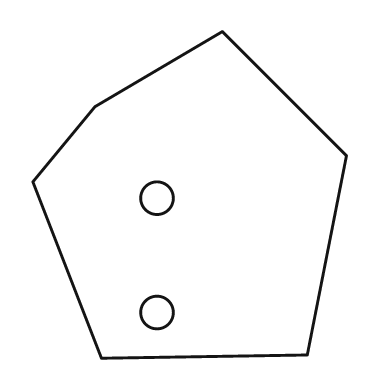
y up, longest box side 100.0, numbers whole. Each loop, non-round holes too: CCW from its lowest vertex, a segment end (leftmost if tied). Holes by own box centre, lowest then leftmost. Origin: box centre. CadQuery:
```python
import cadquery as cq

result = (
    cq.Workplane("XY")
    .moveTo(-27.0, -50.0)
    .lineTo(36.0, -49.0)
    .lineTo(48.0, 12.0)
    .lineTo(10.0, 50.0)
    .lineTo(-29.0, 27.0)
    .lineTo(-48.0, 4.0)
    .close()
    .moveTo(-10.0, -36.0)
    .circle(5.0)
    .moveTo(-10.0, -1.0)
    .circle(5.0)
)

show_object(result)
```